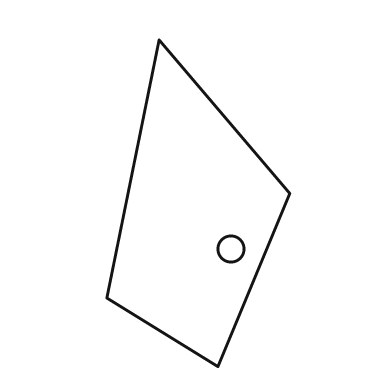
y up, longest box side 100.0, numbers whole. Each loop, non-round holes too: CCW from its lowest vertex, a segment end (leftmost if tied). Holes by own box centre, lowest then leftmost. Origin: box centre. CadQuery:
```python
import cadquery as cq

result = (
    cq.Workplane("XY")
    .moveTo(6.0, -50.0)
    .lineTo(28.0, 3.0)
    .lineTo(-12.0, 50.0)
    .lineTo(-28.0, -29.0)
    .close()
    .moveTo(10.0, -14.0)
    .circle(4.0)
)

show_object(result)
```